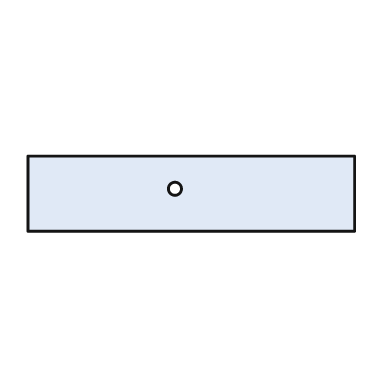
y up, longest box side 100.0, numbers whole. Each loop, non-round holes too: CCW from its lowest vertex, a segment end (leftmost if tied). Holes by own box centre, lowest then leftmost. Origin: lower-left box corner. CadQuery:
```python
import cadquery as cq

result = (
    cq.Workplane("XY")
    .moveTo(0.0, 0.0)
    .lineTo(100.0, 0.0)
    .lineTo(100.0, 23.0)
    .lineTo(0.0, 23.0)
    .close()
    .moveTo(45.0, 13.0)
    .circle(2.0)
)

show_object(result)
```